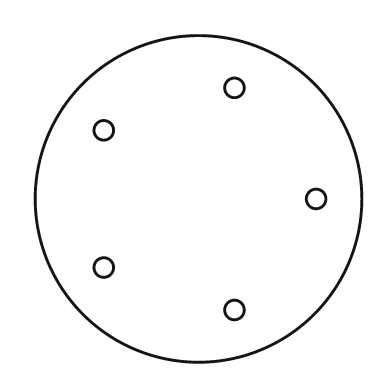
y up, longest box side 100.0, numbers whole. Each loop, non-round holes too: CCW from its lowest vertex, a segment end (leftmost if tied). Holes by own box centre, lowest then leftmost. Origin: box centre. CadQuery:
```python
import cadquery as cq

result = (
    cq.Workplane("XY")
    .moveTo(0.0, 0.0)
    .circle(50.0)
    .moveTo(11.0, -34.0)
    .circle(3.0)
    .moveTo(-29.0, -21.0)
    .circle(3.0)
    .moveTo(36.0, 0.0)
    .circle(3.0)
    .moveTo(-29.0, 21.0)
    .circle(3.0)
    .moveTo(11.0, 34.0)
    .circle(3.0)
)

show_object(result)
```